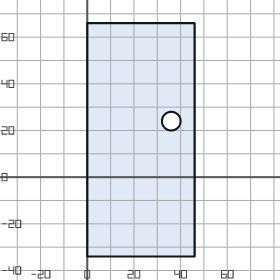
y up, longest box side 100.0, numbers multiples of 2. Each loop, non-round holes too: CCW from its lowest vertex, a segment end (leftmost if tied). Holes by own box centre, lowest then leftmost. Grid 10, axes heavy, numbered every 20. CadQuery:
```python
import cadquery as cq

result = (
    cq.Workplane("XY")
    .moveTo(0.0, -34.0)
    .lineTo(46.0, -34.0)
    .lineTo(46.0, 66.0)
    .lineTo(0.0, 66.0)
    .close()
    .moveTo(36.0, 24.0)
    .circle(4.0)
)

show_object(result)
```